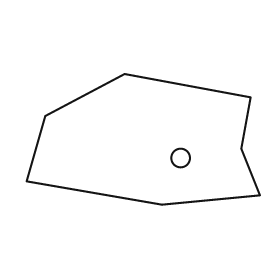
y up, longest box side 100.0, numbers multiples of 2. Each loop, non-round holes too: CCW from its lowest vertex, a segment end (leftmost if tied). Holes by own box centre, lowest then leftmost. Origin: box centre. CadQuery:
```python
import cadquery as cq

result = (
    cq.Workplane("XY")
    .moveTo(8.0, -28.0)
    .lineTo(50.0, -24.0)
    .lineTo(42.0, -4.0)
    .lineTo(46.0, 18.0)
    .lineTo(-8.0, 28.0)
    .lineTo(-42.0, 10.0)
    .lineTo(-50.0, -18.0)
    .close()
    .moveTo(16.0, -8.0)
    .circle(4.0)
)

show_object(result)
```